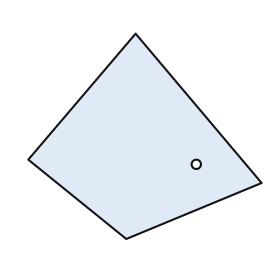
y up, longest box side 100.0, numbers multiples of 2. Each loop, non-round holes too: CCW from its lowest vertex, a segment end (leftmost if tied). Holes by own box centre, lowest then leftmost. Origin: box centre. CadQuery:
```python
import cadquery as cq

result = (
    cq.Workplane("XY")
    .moveTo(-8.0, -44.0)
    .lineTo(50.0, -20.0)
    .lineTo(-4.0, 44.0)
    .lineTo(-50.0, -10.0)
    .close()
    .moveTo(22.0, -12.0)
    .circle(2.0)
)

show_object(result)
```